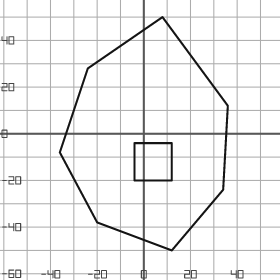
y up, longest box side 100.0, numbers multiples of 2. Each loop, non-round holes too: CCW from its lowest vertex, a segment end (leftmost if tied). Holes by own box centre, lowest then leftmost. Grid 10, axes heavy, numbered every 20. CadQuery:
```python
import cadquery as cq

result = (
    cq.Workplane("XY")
    .moveTo(12.0, -50.0)
    .lineTo(34.0, -24.0)
    .lineTo(36.0, 12.0)
    .lineTo(8.0, 50.0)
    .lineTo(-24.0, 28.0)
    .lineTo(-36.0, -8.0)
    .lineTo(-20.0, -38.0)
    .close()
    .moveTo(-4.0, -20.0)
    .lineTo(12.0, -20.0)
    .lineTo(12.0, -4.0)
    .lineTo(-4.0, -4.0)
    .close()
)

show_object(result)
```